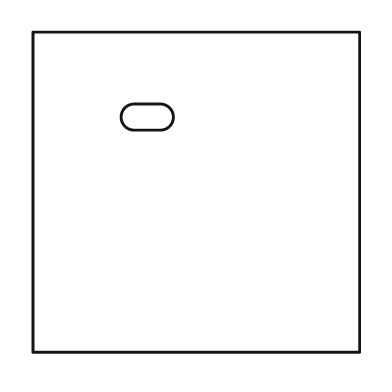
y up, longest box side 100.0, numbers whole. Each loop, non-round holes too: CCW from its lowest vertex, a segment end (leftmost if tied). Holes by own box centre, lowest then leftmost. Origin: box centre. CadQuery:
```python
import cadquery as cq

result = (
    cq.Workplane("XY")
    .moveTo(-50.0, -49.0)
    .lineTo(50.0, -49.0)
    .lineTo(50.0, 49.0)
    .lineTo(-50.0, 49.0)
    .close()
    .moveTo(-19.0, 19.0)
    .lineTo(-11.0, 19.0)
    .threePointArc((-7.0, 23.0), (-11.0, 27.0))
    .lineTo(-19.0, 27.0)
    .threePointArc((-23.0, 23.0), (-19.0, 19.0))
    .close()
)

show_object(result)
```